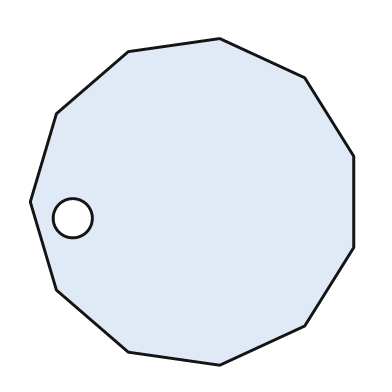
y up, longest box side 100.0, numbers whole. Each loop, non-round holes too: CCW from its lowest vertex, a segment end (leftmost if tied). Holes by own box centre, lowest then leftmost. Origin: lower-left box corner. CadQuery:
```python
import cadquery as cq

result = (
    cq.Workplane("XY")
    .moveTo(58.0, 0.0)
    .lineTo(84.0, 12.0)
    .lineTo(99.0, 36.0)
    .lineTo(99.0, 64.0)
    .lineTo(84.0, 88.0)
    .lineTo(58.0, 100.0)
    .lineTo(30.0, 96.0)
    .lineTo(8.0, 77.0)
    .lineTo(0.0, 50.0)
    .lineTo(8.0, 23.0)
    .lineTo(30.0, 4.0)
    .close()
    .moveTo(13.0, 45.0)
    .circle(6.0)
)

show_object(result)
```